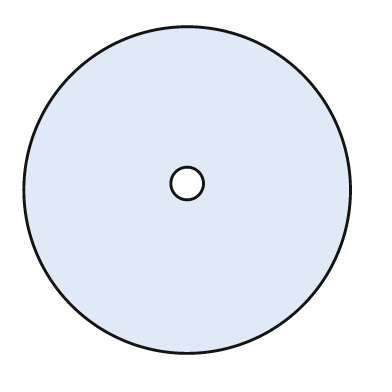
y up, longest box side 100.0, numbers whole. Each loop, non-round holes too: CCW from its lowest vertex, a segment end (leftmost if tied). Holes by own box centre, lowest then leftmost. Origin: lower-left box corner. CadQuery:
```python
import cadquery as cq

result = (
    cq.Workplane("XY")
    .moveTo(50.0, 50.0)
    .circle(50.0)
    .moveTo(50.0, 52.0)
    .circle(5.0)
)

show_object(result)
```